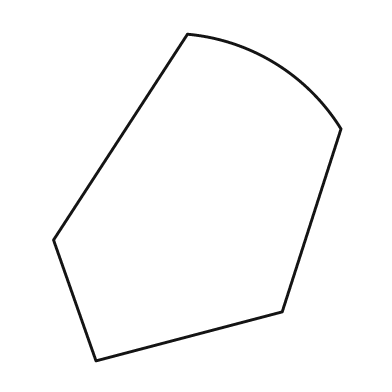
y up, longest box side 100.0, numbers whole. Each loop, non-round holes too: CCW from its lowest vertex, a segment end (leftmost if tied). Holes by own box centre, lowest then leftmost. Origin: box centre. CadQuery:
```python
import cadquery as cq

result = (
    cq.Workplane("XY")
    .moveTo(-31.0, -50.0)
    .lineTo(26.0, -35.0)
    .lineTo(44.0, 21.0)
    .threePointArc((24.0, 41.0), (-3.0, 50.0))
    .lineTo(-44.0, -13.0)
    .close()
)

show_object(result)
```